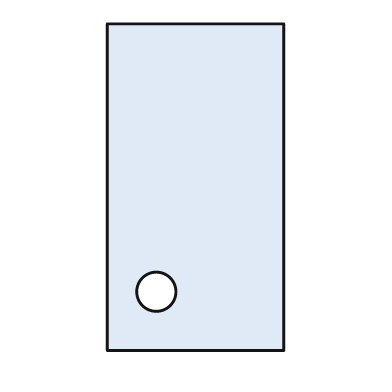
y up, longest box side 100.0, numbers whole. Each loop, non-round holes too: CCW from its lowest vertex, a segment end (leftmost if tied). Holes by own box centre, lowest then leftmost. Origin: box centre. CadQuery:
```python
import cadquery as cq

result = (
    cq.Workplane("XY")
    .moveTo(-27.0, -50.0)
    .lineTo(27.0, -50.0)
    .lineTo(27.0, 50.0)
    .lineTo(-27.0, 50.0)
    .close()
    .moveTo(-12.0, -32.0)
    .circle(6.0)
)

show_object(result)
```